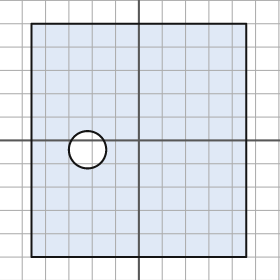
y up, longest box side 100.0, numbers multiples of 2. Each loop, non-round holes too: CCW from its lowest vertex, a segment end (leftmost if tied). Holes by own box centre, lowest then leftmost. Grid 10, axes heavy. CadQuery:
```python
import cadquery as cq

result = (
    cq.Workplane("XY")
    .moveTo(-46.0, -50.0)
    .lineTo(46.0, -50.0)
    .lineTo(46.0, 50.0)
    .lineTo(-46.0, 50.0)
    .close()
    .moveTo(-22.0, -4.0)
    .circle(8.0)
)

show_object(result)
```